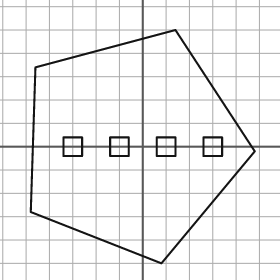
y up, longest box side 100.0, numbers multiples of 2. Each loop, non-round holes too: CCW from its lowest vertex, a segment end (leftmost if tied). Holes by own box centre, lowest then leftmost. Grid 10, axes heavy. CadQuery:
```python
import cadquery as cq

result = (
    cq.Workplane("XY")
    .moveTo(8.0, -50.0)
    .lineTo(48.0, -2.0)
    .lineTo(14.0, 50.0)
    .lineTo(-46.0, 34.0)
    .lineTo(-48.0, -28.0)
    .close()
    .moveTo(-34.0, -4.0)
    .lineTo(-26.0, -4.0)
    .lineTo(-26.0, 4.0)
    .lineTo(-34.0, 4.0)
    .close()
    .moveTo(-14.0, -4.0)
    .lineTo(-6.0, -4.0)
    .lineTo(-6.0, 4.0)
    .lineTo(-14.0, 4.0)
    .close()
    .moveTo(6.0, -4.0)
    .lineTo(14.0, -4.0)
    .lineTo(14.0, 4.0)
    .lineTo(6.0, 4.0)
    .close()
    .moveTo(26.0, -4.0)
    .lineTo(34.0, -4.0)
    .lineTo(34.0, 4.0)
    .lineTo(26.0, 4.0)
    .close()
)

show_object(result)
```